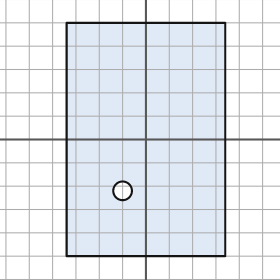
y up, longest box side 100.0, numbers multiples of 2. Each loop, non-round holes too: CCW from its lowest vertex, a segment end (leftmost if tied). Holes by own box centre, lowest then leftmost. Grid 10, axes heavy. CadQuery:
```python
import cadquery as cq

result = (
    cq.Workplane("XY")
    .moveTo(-34.0, -50.0)
    .lineTo(34.0, -50.0)
    .lineTo(34.0, 50.0)
    .lineTo(-34.0, 50.0)
    .close()
    .moveTo(-10.0, -22.0)
    .circle(4.0)
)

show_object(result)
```